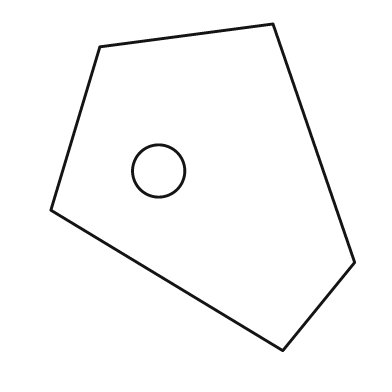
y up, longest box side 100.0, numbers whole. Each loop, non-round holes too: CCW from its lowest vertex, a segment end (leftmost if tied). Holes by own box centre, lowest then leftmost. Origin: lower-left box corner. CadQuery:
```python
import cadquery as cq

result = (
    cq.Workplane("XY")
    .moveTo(71.0, 0.0)
    .lineTo(93.0, 27.0)
    .lineTo(68.0, 100.0)
    .lineTo(15.0, 93.0)
    .lineTo(0.0, 43.0)
    .close()
    .moveTo(33.0, 55.0)
    .circle(8.0)
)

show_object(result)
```